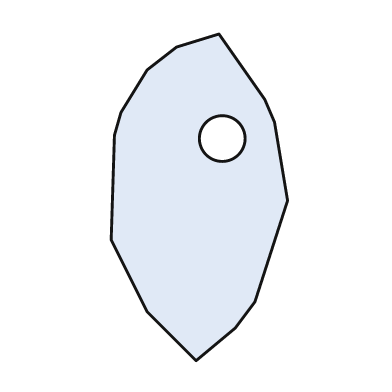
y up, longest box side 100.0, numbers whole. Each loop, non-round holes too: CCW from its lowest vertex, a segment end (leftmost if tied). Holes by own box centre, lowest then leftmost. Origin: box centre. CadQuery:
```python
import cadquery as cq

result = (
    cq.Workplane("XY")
    .moveTo(-1.0, -50.0)
    .lineTo(11.0, -40.0)
    .lineTo(17.0, -32.0)
    .lineTo(27.0, -1.0)
    .lineTo(23.0, 23.0)
    .lineTo(20.0, 30.0)
    .lineTo(6.0, 50.0)
    .lineTo(-7.0, 46.0)
    .lineTo(-16.0, 39.0)
    .lineTo(-24.0, 26.0)
    .lineTo(-26.0, 19.0)
    .lineTo(-27.0, -13.0)
    .lineTo(-16.0, -35.0)
    .close()
    .moveTo(7.0, 18.0)
    .circle(7.0)
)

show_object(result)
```